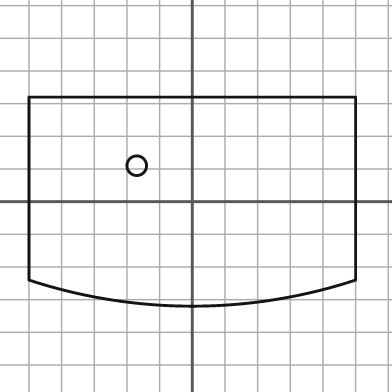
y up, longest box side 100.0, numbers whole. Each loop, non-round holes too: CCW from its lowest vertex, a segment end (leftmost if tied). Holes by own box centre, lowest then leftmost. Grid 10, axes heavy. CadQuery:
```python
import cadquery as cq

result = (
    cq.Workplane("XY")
    .moveTo(-50.0, -24.0)
    .threePointArc((0.0, -32.0), (50.0, -24.0))
    .lineTo(50.0, 32.0)
    .lineTo(-50.0, 32.0)
    .close()
    .moveTo(-17.0, 11.0)
    .circle(3.0)
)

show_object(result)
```